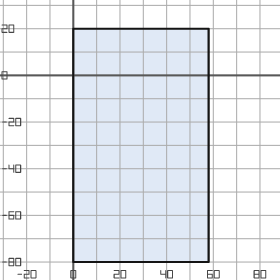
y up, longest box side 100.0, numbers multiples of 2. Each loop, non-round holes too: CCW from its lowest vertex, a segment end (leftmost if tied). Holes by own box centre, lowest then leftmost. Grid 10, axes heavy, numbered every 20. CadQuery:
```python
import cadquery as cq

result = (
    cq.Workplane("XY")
    .moveTo(0.0, -80.0)
    .lineTo(58.0, -80.0)
    .lineTo(58.0, 20.0)
    .lineTo(0.0, 20.0)
    .close()
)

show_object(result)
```